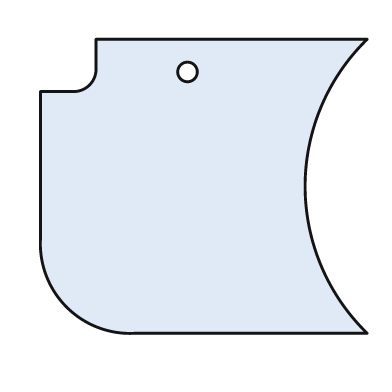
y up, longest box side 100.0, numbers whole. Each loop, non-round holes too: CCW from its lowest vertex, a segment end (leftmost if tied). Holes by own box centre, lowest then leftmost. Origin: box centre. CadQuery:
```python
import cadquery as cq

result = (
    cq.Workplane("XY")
    .moveTo(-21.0, -45.0)
    .lineTo(50.0, -45.0)
    .threePointArc((31.0, 0.0), (50.0, 45.0))
    .lineTo(-33.0, 45.0)
    .lineTo(-33.0, 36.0)
    .threePointArc((-35.0, 31.0), (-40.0, 29.0))
    .lineTo(-50.0, 29.0)
    .lineTo(-50.0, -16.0)
    .threePointArc((-42.0, -37.0), (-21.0, -45.0))
    .close()
    .moveTo(-5.0, 35.0)
    .circle(3.0)
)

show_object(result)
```